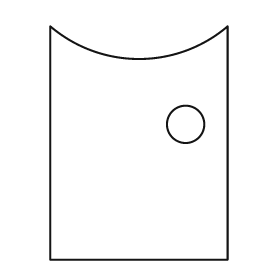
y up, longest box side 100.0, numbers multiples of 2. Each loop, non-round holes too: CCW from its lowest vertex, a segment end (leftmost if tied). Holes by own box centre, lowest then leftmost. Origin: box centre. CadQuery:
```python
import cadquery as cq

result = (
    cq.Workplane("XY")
    .moveTo(-38.0, -50.0)
    .lineTo(38.0, -50.0)
    .lineTo(38.0, 50.0)
    .threePointArc((0.0, 36.0), (-38.0, 50.0))
    .close()
    .moveTo(20.0, 8.0)
    .circle(8.0)
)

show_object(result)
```